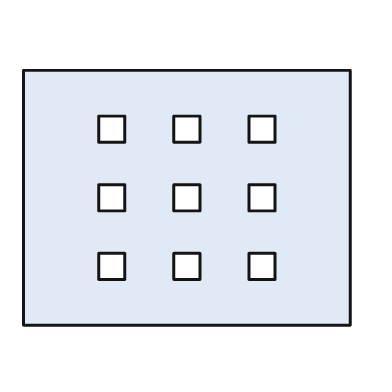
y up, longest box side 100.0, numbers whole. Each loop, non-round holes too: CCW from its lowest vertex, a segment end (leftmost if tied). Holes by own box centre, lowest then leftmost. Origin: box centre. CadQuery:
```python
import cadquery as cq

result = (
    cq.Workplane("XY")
    .moveTo(-50.0, -39.0)
    .lineTo(50.0, -39.0)
    .lineTo(50.0, 39.0)
    .lineTo(-50.0, 39.0)
    .close()
    .moveTo(-27.0, -25.0)
    .lineTo(-19.0, -25.0)
    .lineTo(-19.0, -17.0)
    .lineTo(-27.0, -17.0)
    .close()
    .moveTo(-4.0, -25.0)
    .lineTo(4.0, -25.0)
    .lineTo(4.0, -17.0)
    .lineTo(-4.0, -17.0)
    .close()
    .moveTo(19.0, -25.0)
    .lineTo(27.0, -25.0)
    .lineTo(27.0, -17.0)
    .lineTo(19.0, -17.0)
    .close()
    .moveTo(-27.0, -4.0)
    .lineTo(-19.0, -4.0)
    .lineTo(-19.0, 4.0)
    .lineTo(-27.0, 4.0)
    .close()
    .moveTo(-4.0, -4.0)
    .lineTo(4.0, -4.0)
    .lineTo(4.0, 4.0)
    .lineTo(-4.0, 4.0)
    .close()
    .moveTo(19.0, -4.0)
    .lineTo(27.0, -4.0)
    .lineTo(27.0, 4.0)
    .lineTo(19.0, 4.0)
    .close()
    .moveTo(-27.0, 17.0)
    .lineTo(-19.0, 17.0)
    .lineTo(-19.0, 25.0)
    .lineTo(-27.0, 25.0)
    .close()
    .moveTo(-4.0, 17.0)
    .lineTo(4.0, 17.0)
    .lineTo(4.0, 25.0)
    .lineTo(-4.0, 25.0)
    .close()
    .moveTo(19.0, 17.0)
    .lineTo(27.0, 17.0)
    .lineTo(27.0, 25.0)
    .lineTo(19.0, 25.0)
    .close()
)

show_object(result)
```